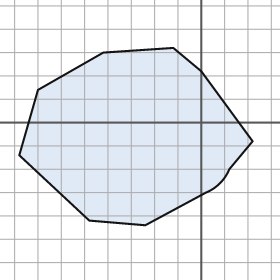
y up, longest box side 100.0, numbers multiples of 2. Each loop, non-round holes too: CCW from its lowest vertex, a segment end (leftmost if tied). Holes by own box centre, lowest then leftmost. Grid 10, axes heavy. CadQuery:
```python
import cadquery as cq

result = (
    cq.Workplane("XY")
    .moveTo(-24.0, -44.0)
    .lineTo(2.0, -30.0)
    .threePointArc((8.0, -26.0), (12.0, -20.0))
    .lineTo(22.0, -8.0)
    .lineTo(0.0, 22.0)
    .lineTo(-12.0, 32.0)
    .lineTo(-42.0, 30.0)
    .lineTo(-70.0, 14.0)
    .lineTo(-78.0, -14.0)
    .lineTo(-48.0, -42.0)
    .close()
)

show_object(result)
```